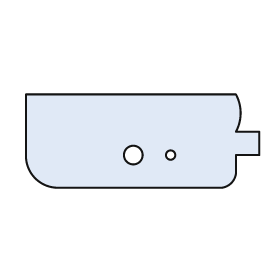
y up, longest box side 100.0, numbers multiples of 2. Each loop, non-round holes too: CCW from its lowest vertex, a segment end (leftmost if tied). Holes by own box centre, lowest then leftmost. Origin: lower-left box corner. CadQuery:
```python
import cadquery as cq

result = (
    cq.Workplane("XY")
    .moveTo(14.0, 0.0)
    .lineTo(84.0, 0.0)
    .threePointArc((88.0, 2.0), (90.0, 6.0))
    .lineTo(90.0, 14.0)
    .lineTo(100.0, 14.0)
    .lineTo(100.0, 24.0)
    .lineTo(90.0, 24.0)
    .threePointArc((92.0, 32.0), (90.0, 40.0))
    .lineTo(0.0, 40.0)
    .lineTo(0.0, 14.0)
    .threePointArc((4.0, 4.0), (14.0, 0.0))
    .close()
    .moveTo(46.0, 14.0)
    .circle(4.0)
    .moveTo(62.0, 14.0)
    .circle(2.0)
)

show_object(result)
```